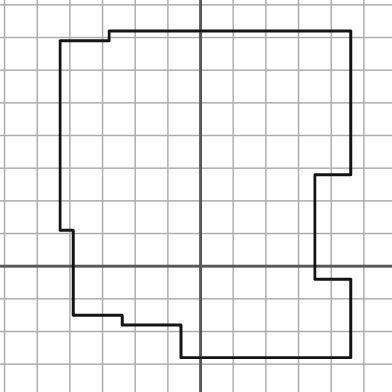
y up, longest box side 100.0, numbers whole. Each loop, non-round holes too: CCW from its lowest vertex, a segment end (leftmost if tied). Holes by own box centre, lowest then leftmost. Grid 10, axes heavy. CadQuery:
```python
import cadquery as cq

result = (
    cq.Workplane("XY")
    .moveTo(-6.0, -28.0)
    .lineTo(46.0, -28.0)
    .lineTo(46.0, -4.0)
    .lineTo(35.0, -4.0)
    .lineTo(35.0, 28.0)
    .lineTo(46.0, 28.0)
    .lineTo(46.0, 72.0)
    .lineTo(-28.0, 72.0)
    .lineTo(-28.0, 69.0)
    .lineTo(-43.0, 69.0)
    .lineTo(-43.0, 11.0)
    .lineTo(-39.0, 11.0)
    .lineTo(-39.0, -15.0)
    .lineTo(-24.0, -15.0)
    .lineTo(-24.0, -18.0)
    .lineTo(-6.0, -18.0)
    .close()
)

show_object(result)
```